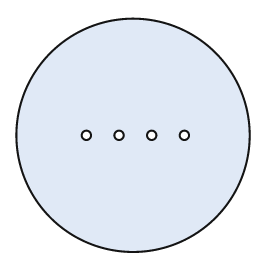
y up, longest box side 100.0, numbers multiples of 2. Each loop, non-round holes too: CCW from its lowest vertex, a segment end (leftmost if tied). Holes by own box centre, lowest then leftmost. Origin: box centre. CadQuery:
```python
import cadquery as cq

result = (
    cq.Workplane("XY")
    .moveTo(0.0, 0.0)
    .circle(50.0)
    .moveTo(-20.0, 0.0)
    .circle(2.0)
    .moveTo(-6.0, 0.0)
    .circle(2.0)
    .moveTo(8.0, 0.0)
    .circle(2.0)
    .moveTo(22.0, 0.0)
    .circle(2.0)
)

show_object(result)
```